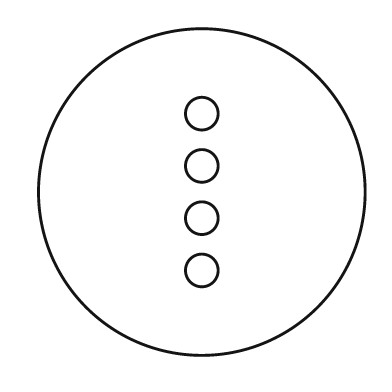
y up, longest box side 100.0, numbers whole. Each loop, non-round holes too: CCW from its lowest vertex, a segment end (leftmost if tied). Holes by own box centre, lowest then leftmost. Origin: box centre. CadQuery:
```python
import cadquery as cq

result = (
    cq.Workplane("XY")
    .moveTo(0.0, 0.0)
    .circle(50.0)
    .moveTo(0.0, -24.0)
    .circle(5.0)
    .moveTo(0.0, -8.0)
    .circle(5.0)
    .moveTo(0.0, 8.0)
    .circle(5.0)
    .moveTo(0.0, 24.0)
    .circle(5.0)
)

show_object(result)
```